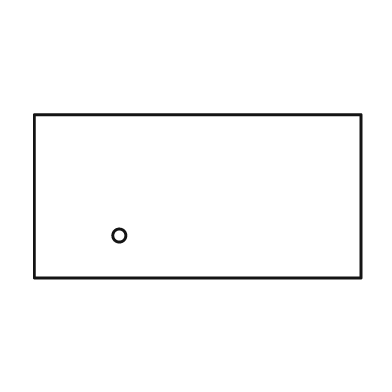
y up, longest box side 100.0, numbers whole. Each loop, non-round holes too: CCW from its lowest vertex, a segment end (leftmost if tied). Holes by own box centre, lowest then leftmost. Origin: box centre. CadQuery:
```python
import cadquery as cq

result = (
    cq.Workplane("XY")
    .moveTo(-50.0, -25.0)
    .lineTo(50.0, -25.0)
    .lineTo(50.0, 25.0)
    .lineTo(-50.0, 25.0)
    .close()
    .moveTo(-24.0, -12.0)
    .circle(2.0)
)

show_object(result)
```